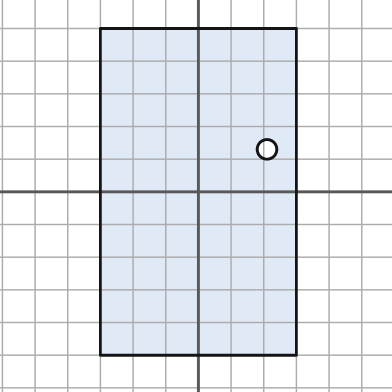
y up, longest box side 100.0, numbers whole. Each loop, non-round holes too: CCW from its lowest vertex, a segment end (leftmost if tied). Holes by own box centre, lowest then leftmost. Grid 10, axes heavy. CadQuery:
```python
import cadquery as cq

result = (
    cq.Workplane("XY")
    .moveTo(-30.0, -50.0)
    .lineTo(30.0, -50.0)
    .lineTo(30.0, 50.0)
    .lineTo(-30.0, 50.0)
    .close()
    .moveTo(21.0, 13.0)
    .circle(3.0)
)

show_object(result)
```